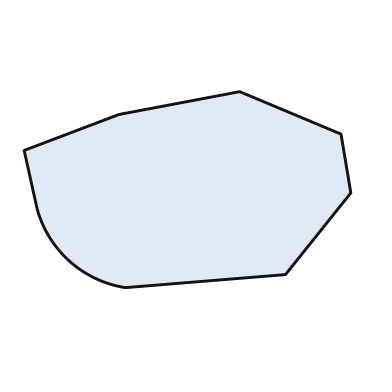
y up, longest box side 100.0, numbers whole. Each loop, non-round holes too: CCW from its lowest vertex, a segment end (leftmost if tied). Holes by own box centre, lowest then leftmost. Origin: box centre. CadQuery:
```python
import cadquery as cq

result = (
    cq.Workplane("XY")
    .moveTo(-19.0, -30.0)
    .lineTo(30.0, -26.0)
    .lineTo(50.0, -1.0)
    .lineTo(47.0, 17.0)
    .lineTo(16.0, 30.0)
    .lineTo(-21.0, 23.0)
    .lineTo(-50.0, 12.0)
    .lineTo(-46.0, -6.0)
    .threePointArc((-36.0, -22.0), (-19.0, -30.0))
    .close()
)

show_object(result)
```